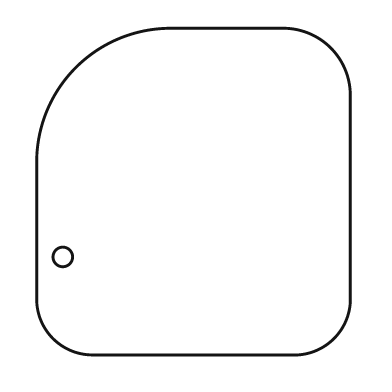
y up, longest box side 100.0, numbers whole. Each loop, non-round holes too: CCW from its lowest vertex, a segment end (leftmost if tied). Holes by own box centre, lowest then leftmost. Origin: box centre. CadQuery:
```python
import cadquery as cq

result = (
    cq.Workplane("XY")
    .moveTo(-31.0, -50.0)
    .lineTo(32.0, -50.0)
    .threePointArc((43.0, -45.0), (48.0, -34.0))
    .lineTo(48.0, 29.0)
    .threePointArc((42.0, 44.0), (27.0, 50.0))
    .lineTo(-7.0, 50.0)
    .threePointArc((-36.0, 38.0), (-48.0, 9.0))
    .lineTo(-48.0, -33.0)
    .threePointArc((-43.0, -45.0), (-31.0, -50.0))
    .close()
    .moveTo(-40.0, -20.0)
    .circle(3.0)
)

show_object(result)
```